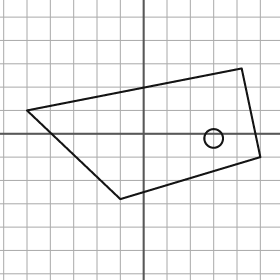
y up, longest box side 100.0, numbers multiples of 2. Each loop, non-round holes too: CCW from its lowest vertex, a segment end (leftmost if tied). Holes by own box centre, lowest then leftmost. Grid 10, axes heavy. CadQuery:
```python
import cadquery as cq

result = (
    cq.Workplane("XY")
    .moveTo(-10.0, -28.0)
    .lineTo(50.0, -10.0)
    .lineTo(42.0, 28.0)
    .lineTo(-50.0, 10.0)
    .close()
    .moveTo(30.0, -2.0)
    .circle(4.0)
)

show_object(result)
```